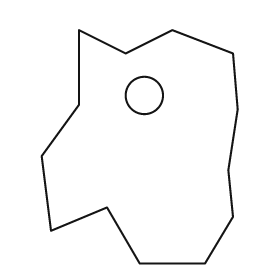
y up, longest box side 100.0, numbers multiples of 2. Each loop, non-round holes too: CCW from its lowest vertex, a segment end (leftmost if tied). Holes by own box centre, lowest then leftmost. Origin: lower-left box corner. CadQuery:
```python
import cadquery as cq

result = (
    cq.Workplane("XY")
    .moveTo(42.0, 0.0)
    .lineTo(70.0, 0.0)
    .lineTo(82.0, 20.0)
    .lineTo(80.0, 40.0)
    .lineTo(84.0, 66.0)
    .lineTo(82.0, 90.0)
    .lineTo(56.0, 100.0)
    .lineTo(36.0, 90.0)
    .lineTo(16.0, 100.0)
    .lineTo(16.0, 68.0)
    .lineTo(0.0, 46.0)
    .lineTo(4.0, 14.0)
    .lineTo(28.0, 24.0)
    .close()
    .moveTo(44.0, 72.0)
    .circle(8.0)
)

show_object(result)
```